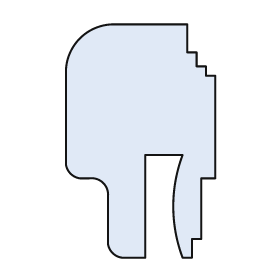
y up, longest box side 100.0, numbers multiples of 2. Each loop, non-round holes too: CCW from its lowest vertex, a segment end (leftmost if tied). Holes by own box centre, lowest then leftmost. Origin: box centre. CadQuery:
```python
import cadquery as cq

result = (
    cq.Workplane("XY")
    .moveTo(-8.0, -50.0)
    .lineTo(2.0, -50.0)
    .lineTo(2.0, -6.0)
    .lineTo(18.0, -6.0)
    .threePointArc((14.0, -28.0), (18.0, -50.0))
    .lineTo(22.0, -50.0)
    .lineTo(22.0, -42.0)
    .lineTo(26.0, -42.0)
    .lineTo(26.0, -16.0)
    .lineTo(32.0, -16.0)
    .lineTo(32.0, 28.0)
    .lineTo(28.0, 28.0)
    .lineTo(28.0, 32.0)
    .lineTo(24.0, 32.0)
    .lineTo(24.0, 38.0)
    .lineTo(20.0, 38.0)
    .lineTo(20.0, 50.0)
    .lineTo(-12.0, 50.0)
    .threePointArc((-26.0, 44.0), (-32.0, 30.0))
    .lineTo(-32.0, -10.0)
    .threePointArc((-30.0, -14.0), (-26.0, -16.0))
    .lineTo(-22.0, -16.0)
    .threePointArc((-16.0, -18.0), (-14.0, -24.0))
    .lineTo(-14.0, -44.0)
    .threePointArc((-12.0, -48.0), (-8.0, -50.0))
    .close()
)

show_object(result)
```